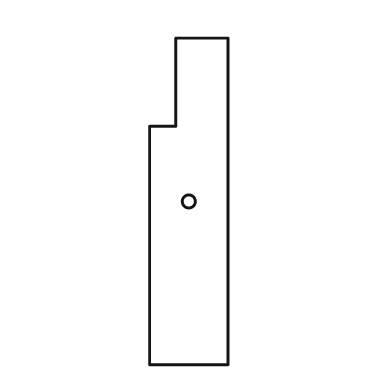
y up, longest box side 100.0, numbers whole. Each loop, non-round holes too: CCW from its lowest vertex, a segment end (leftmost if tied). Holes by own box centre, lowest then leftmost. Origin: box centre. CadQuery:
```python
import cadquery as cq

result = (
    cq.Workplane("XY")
    .moveTo(-12.0, -50.0)
    .lineTo(12.0, -50.0)
    .lineTo(12.0, 50.0)
    .lineTo(-4.0, 50.0)
    .lineTo(-4.0, 23.0)
    .lineTo(-12.0, 23.0)
    .close()
    .moveTo(0.0, 0.0)
    .circle(2.0)
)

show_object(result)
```